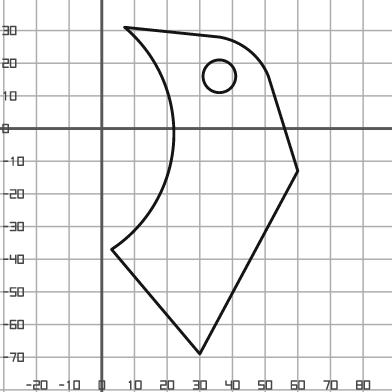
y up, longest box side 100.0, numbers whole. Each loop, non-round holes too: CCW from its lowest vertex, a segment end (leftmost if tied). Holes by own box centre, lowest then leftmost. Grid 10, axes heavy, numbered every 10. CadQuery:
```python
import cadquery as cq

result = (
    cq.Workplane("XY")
    .moveTo(30.0, -69.0)
    .lineTo(60.0, -13.0)
    .lineTo(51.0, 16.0)
    .threePointArc((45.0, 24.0), (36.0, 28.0))
    .lineTo(7.0, 31.0)
    .threePointArc((22.0, -4.0), (3.0, -37.0))
    .close()
    .moveTo(36.0, 16.0)
    .circle(5.0)
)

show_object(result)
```